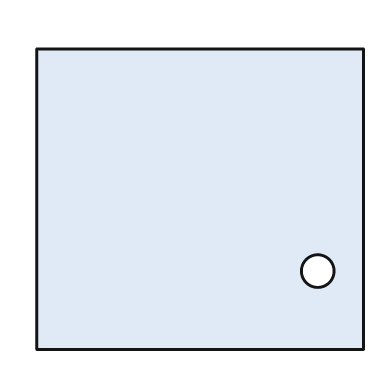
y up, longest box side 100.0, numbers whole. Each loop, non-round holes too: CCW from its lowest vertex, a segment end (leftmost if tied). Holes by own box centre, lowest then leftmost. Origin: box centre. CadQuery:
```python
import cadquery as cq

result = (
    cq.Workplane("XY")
    .moveTo(-50.0, -46.0)
    .lineTo(50.0, -46.0)
    .lineTo(50.0, 46.0)
    .lineTo(-50.0, 46.0)
    .close()
    .moveTo(36.0, -22.0)
    .circle(5.0)
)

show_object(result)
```